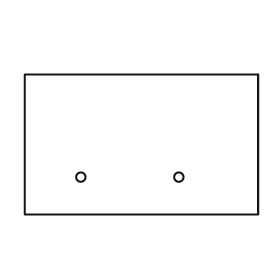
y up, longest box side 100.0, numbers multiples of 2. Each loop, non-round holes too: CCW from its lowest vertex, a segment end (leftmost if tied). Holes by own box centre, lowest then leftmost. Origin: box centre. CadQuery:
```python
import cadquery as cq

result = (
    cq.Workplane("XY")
    .moveTo(-50.0, -30.0)
    .lineTo(50.0, -30.0)
    .lineTo(50.0, 30.0)
    .lineTo(-50.0, 30.0)
    .close()
    .moveTo(-26.0, -14.0)
    .circle(2.0)
    .moveTo(16.0, -14.0)
    .circle(2.0)
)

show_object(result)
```